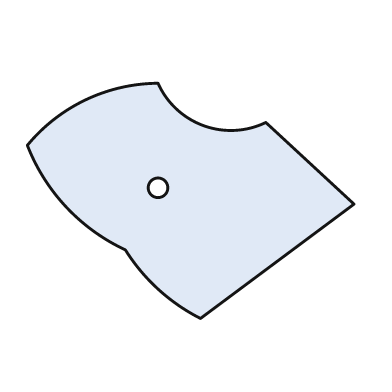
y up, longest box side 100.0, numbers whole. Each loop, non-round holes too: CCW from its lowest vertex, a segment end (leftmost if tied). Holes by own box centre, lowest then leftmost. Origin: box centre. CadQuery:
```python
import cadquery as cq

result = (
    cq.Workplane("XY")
    .moveTo(3.0, -36.0)
    .lineTo(50.0, -1.0)
    .lineTo(23.0, 24.0)
    .threePointArc((4.0, 23.0), (-10.0, 36.0))
    .threePointArc((-32.0, 31.0), (-50.0, 17.0))
    .threePointArc((-38.0, -2.0), (-20.0, -15.0))
    .threePointArc((-10.0, -27.0), (3.0, -36.0))
    .close()
    .moveTo(-10.0, 4.0)
    .circle(3.0)
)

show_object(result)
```